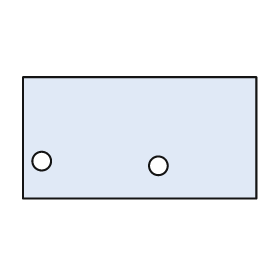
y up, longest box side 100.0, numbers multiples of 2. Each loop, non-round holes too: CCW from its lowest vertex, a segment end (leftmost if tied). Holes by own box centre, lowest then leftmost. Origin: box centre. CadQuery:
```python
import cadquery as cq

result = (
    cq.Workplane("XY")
    .moveTo(-50.0, -26.0)
    .lineTo(50.0, -26.0)
    .lineTo(50.0, 26.0)
    .lineTo(-50.0, 26.0)
    .close()
    .moveTo(8.0, -12.0)
    .circle(4.0)
    .moveTo(-42.0, -10.0)
    .circle(4.0)
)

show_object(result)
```